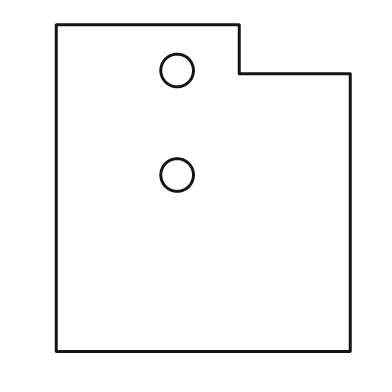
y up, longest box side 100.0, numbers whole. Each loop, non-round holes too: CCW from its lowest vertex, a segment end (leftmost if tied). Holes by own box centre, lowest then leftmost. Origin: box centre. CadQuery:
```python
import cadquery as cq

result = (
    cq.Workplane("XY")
    .moveTo(-45.0, -50.0)
    .lineTo(45.0, -50.0)
    .lineTo(45.0, 35.0)
    .lineTo(11.0, 35.0)
    .lineTo(11.0, 50.0)
    .lineTo(-45.0, 50.0)
    .close()
    .moveTo(-8.0, 4.0)
    .circle(5.0)
    .moveTo(-8.0, 36.0)
    .circle(5.0)
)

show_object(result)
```